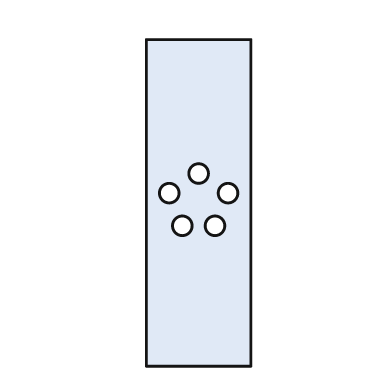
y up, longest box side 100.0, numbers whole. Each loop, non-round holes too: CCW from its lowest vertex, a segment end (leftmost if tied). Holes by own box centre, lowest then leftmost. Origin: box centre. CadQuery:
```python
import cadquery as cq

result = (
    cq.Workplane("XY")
    .moveTo(-16.0, -50.0)
    .lineTo(16.0, -50.0)
    .lineTo(16.0, 50.0)
    .lineTo(-16.0, 50.0)
    .close()
    .moveTo(-5.0, -7.0)
    .circle(3.0)
    .moveTo(5.0, -7.0)
    .circle(3.0)
    .moveTo(-9.0, 3.0)
    .circle(3.0)
    .moveTo(9.0, 3.0)
    .circle(3.0)
    .moveTo(0.0, 9.0)
    .circle(3.0)
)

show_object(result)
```